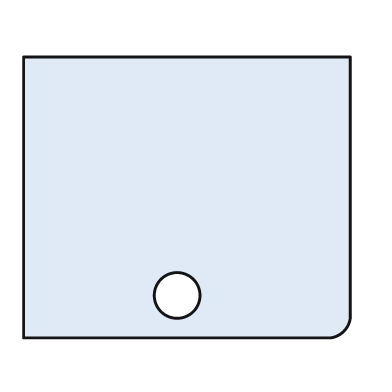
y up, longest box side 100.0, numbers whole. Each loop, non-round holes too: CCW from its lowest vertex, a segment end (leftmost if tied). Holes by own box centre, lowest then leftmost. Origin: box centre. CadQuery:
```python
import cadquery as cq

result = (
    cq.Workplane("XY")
    .moveTo(-50.0, -43.0)
    .lineTo(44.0, -43.0)
    .threePointArc((48.0, -41.0), (50.0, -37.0))
    .lineTo(50.0, 43.0)
    .lineTo(-50.0, 43.0)
    .close()
    .moveTo(-3.0, -30.0)
    .circle(7.0)
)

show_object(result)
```